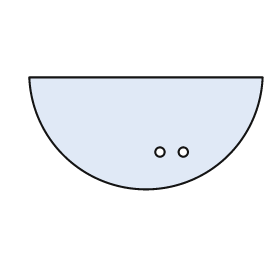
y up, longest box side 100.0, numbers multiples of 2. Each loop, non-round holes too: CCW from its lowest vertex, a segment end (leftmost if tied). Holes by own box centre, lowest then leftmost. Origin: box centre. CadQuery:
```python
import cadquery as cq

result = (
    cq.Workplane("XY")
    .moveTo(-50.0, 24.0)
    .threePointArc((0.0, -24.0), (50.0, 24.0))
    .close()
    .moveTo(6.0, -8.0)
    .circle(2.0)
    .moveTo(16.0, -8.0)
    .circle(2.0)
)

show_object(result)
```